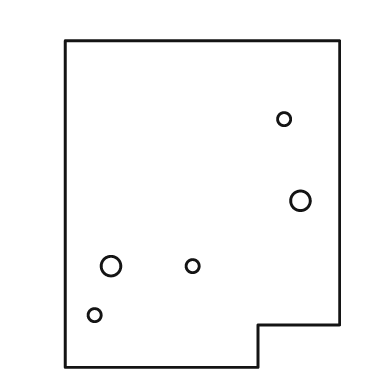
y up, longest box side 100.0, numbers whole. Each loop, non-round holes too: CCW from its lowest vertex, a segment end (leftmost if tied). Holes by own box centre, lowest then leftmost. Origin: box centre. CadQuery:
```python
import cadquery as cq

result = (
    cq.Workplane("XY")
    .moveTo(-42.0, -50.0)
    .lineTo(17.0, -50.0)
    .lineTo(17.0, -37.0)
    .lineTo(42.0, -37.0)
    .lineTo(42.0, 50.0)
    .lineTo(-42.0, 50.0)
    .close()
    .moveTo(-33.0, -34.0)
    .circle(2.0)
    .moveTo(-28.0, -19.0)
    .circle(3.0)
    .moveTo(-3.0, -19.0)
    .circle(2.0)
    .moveTo(30.0, 1.0)
    .circle(3.0)
    .moveTo(25.0, 26.0)
    .circle(2.0)
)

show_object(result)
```